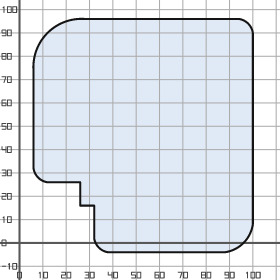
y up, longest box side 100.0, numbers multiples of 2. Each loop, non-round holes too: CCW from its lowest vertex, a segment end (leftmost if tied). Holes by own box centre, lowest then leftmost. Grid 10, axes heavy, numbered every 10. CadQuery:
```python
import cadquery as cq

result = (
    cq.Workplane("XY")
    .moveTo(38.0, -4.0)
    .lineTo(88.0, -4.0)
    .threePointArc((96.0, 0.0), (100.0, 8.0))
    .lineTo(100.0, 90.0)
    .threePointArc((98.0, 94.0), (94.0, 96.0))
    .lineTo(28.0, 96.0)
    .threePointArc((12.0, 90.0), (6.0, 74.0))
    .lineTo(6.0, 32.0)
    .threePointArc((8.0, 28.0), (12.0, 26.0))
    .lineTo(26.0, 26.0)
    .lineTo(26.0, 16.0)
    .lineTo(32.0, 16.0)
    .lineTo(32.0, 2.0)
    .threePointArc((34.0, -2.0), (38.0, -4.0))
    .close()
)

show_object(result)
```